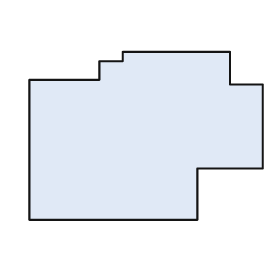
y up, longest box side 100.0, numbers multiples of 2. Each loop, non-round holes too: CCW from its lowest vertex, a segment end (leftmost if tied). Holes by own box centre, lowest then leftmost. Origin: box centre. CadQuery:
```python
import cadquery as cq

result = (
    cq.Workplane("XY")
    .moveTo(-50.0, -36.0)
    .lineTo(22.0, -36.0)
    .lineTo(22.0, -14.0)
    .lineTo(50.0, -14.0)
    .lineTo(50.0, 22.0)
    .lineTo(36.0, 22.0)
    .lineTo(36.0, 36.0)
    .lineTo(-10.0, 36.0)
    .lineTo(-10.0, 32.0)
    .lineTo(-20.0, 32.0)
    .lineTo(-20.0, 24.0)
    .lineTo(-50.0, 24.0)
    .close()
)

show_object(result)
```